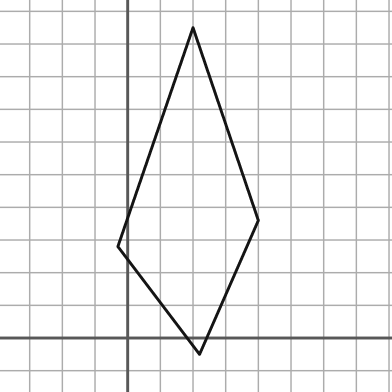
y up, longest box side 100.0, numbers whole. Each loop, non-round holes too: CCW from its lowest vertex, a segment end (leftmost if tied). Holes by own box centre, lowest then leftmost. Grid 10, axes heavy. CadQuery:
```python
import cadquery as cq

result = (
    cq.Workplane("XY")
    .moveTo(22.0, -5.0)
    .lineTo(40.0, 36.0)
    .lineTo(20.0, 95.0)
    .lineTo(-3.0, 28.0)
    .close()
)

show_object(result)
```